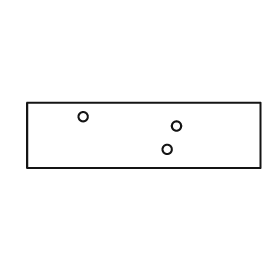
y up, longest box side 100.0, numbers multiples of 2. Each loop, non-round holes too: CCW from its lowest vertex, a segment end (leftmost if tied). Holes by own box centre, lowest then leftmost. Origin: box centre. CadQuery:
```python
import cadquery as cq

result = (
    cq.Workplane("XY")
    .moveTo(-50.0, -14.0)
    .lineTo(50.0, -14.0)
    .lineTo(50.0, 14.0)
    .lineTo(-50.0, 14.0)
    .close()
    .moveTo(10.0, -6.0)
    .circle(2.0)
    .moveTo(14.0, 4.0)
    .circle(2.0)
    .moveTo(-26.0, 8.0)
    .circle(2.0)
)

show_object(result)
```